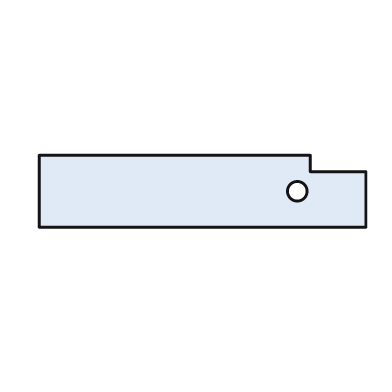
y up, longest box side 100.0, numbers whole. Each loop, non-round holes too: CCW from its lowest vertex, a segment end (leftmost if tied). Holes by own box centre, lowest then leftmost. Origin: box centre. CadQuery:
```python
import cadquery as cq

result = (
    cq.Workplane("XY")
    .moveTo(-50.0, -11.0)
    .lineTo(50.0, -11.0)
    .lineTo(50.0, 6.0)
    .lineTo(33.0, 6.0)
    .lineTo(33.0, 11.0)
    .lineTo(-50.0, 11.0)
    .close()
    .moveTo(29.0, 0.0)
    .circle(3.0)
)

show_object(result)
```